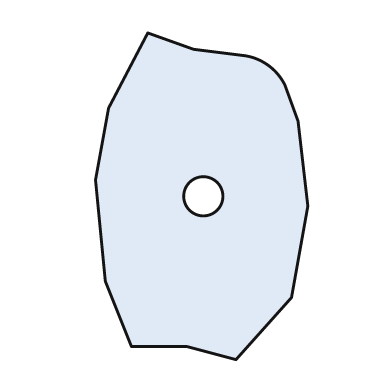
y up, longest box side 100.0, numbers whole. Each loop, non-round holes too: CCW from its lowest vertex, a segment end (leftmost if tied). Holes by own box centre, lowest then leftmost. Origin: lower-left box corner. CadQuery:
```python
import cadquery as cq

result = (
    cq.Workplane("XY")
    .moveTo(43.0, 0.0)
    .lineTo(60.0, 19.0)
    .lineTo(65.0, 47.0)
    .lineTo(62.0, 73.0)
    .lineTo(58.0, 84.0)
    .threePointArc((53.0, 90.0), (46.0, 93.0))
    .lineTo(30.0, 95.0)
    .lineTo(16.0, 100.0)
    .lineTo(4.0, 77.0)
    .lineTo(0.0, 55.0)
    .lineTo(3.0, 24.0)
    .lineTo(11.0, 4.0)
    .lineTo(28.0, 4.0)
    .close()
    .moveTo(33.0, 50.0)
    .circle(6.0)
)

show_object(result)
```